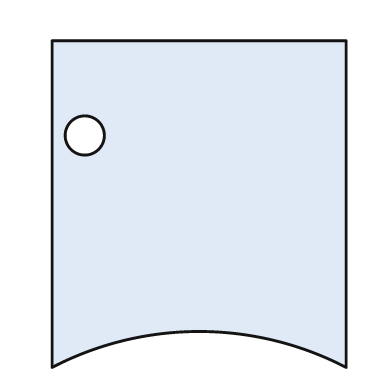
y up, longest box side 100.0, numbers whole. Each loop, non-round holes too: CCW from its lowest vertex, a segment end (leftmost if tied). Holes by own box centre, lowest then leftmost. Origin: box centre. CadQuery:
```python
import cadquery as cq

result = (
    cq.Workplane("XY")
    .moveTo(-45.0, -50.0)
    .threePointArc((0.0, -39.0), (45.0, -50.0))
    .lineTo(45.0, 50.0)
    .lineTo(-45.0, 50.0)
    .close()
    .moveTo(-35.0, 21.0)
    .circle(6.0)
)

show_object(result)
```